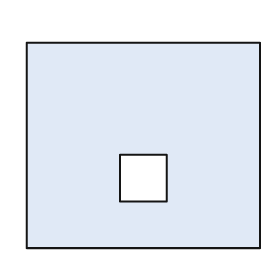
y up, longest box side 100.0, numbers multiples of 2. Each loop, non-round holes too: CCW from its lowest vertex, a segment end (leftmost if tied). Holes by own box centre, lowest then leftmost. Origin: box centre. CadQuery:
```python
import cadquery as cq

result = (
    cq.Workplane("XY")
    .moveTo(-50.0, -44.0)
    .lineTo(50.0, -44.0)
    .lineTo(50.0, 44.0)
    .lineTo(-50.0, 44.0)
    .close()
    .moveTo(-10.0, -24.0)
    .lineTo(10.0, -24.0)
    .lineTo(10.0, -4.0)
    .lineTo(-10.0, -4.0)
    .close()
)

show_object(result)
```